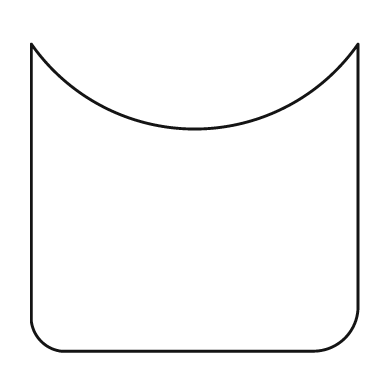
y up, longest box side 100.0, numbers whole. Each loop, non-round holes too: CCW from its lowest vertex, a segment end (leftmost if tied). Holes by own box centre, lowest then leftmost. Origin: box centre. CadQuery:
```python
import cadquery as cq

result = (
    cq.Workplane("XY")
    .moveTo(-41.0, -47.0)
    .lineTo(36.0, -47.0)
    .threePointArc((46.0, -43.0), (50.0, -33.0))
    .lineTo(50.0, 47.0)
    .threePointArc((0.0, 21.0), (-50.0, 47.0))
    .lineTo(-50.0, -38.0)
    .threePointArc((-47.0, -44.0), (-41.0, -47.0))
    .close()
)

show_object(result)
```